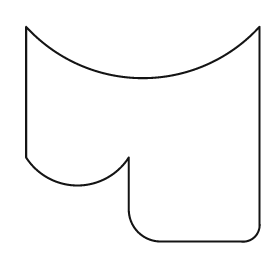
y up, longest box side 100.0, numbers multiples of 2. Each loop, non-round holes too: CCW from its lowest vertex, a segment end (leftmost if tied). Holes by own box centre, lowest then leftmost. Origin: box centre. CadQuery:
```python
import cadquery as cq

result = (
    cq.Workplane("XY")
    .moveTo(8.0, -46.0)
    .lineTo(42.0, -46.0)
    .threePointArc((48.0, -44.0), (50.0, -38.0))
    .lineTo(50.0, 46.0)
    .threePointArc((0.0, 24.0), (-50.0, 46.0))
    .lineTo(-50.0, -10.0)
    .threePointArc((-28.0, -22.0), (-6.0, -10.0))
    .lineTo(-6.0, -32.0)
    .threePointArc((-2.0, -42.0), (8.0, -46.0))
    .close()
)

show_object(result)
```